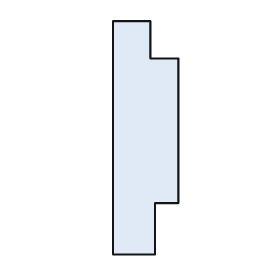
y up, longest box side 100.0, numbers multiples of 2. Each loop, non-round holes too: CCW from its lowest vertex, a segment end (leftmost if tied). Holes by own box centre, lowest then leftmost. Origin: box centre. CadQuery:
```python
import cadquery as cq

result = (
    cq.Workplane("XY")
    .moveTo(-14.0, -50.0)
    .lineTo(4.0, -50.0)
    .lineTo(4.0, -28.0)
    .lineTo(14.0, -28.0)
    .lineTo(14.0, 34.0)
    .lineTo(2.0, 34.0)
    .lineTo(2.0, 50.0)
    .lineTo(-14.0, 50.0)
    .close()
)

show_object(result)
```